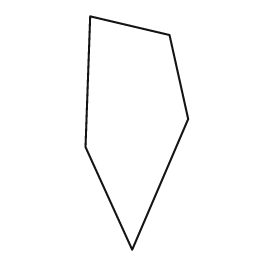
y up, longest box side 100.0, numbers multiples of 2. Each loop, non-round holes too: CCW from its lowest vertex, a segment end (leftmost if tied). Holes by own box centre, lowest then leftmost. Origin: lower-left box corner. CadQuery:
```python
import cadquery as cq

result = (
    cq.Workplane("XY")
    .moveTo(20.0, 0.0)
    .lineTo(44.0, 56.0)
    .lineTo(36.0, 92.0)
    .lineTo(2.0, 100.0)
    .lineTo(0.0, 44.0)
    .close()
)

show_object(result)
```